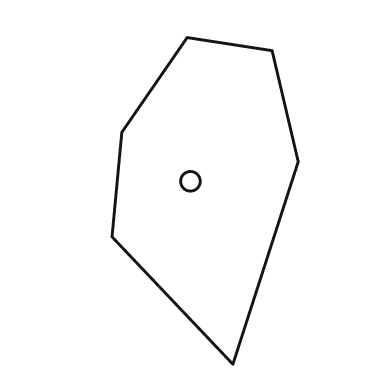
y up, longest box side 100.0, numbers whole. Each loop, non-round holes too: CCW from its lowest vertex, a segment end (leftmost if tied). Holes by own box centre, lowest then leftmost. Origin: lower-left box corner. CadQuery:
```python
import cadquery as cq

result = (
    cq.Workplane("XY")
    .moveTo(37.0, 0.0)
    .lineTo(57.0, 62.0)
    .lineTo(49.0, 96.0)
    .lineTo(23.0, 100.0)
    .lineTo(3.0, 71.0)
    .lineTo(0.0, 39.0)
    .close()
    .moveTo(24.0, 56.0)
    .circle(3.0)
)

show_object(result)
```